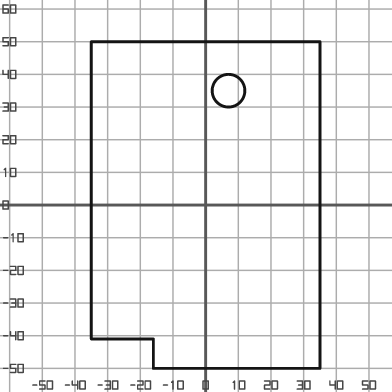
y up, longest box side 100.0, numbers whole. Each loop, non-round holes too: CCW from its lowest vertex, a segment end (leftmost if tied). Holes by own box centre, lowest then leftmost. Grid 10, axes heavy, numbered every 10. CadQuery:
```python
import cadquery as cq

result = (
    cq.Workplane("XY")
    .moveTo(-16.0, -50.0)
    .lineTo(35.0, -50.0)
    .lineTo(35.0, 50.0)
    .lineTo(-35.0, 50.0)
    .lineTo(-35.0, -41.0)
    .lineTo(-16.0, -41.0)
    .close()
    .moveTo(7.0, 35.0)
    .circle(5.0)
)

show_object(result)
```